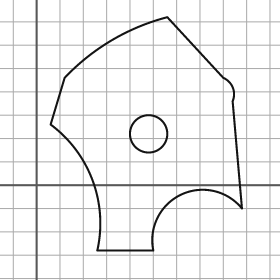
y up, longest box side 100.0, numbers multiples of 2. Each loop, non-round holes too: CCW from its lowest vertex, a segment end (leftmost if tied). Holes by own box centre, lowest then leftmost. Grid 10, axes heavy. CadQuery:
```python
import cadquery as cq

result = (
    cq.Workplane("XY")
    .moveTo(26.0, -28.0)
    .lineTo(50.0, -28.0)
    .threePointArc((62.0, -4.0), (88.0, -10.0))
    .lineTo(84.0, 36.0)
    .threePointArc((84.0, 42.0), (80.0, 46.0))
    .lineTo(56.0, 72.0)
    .threePointArc((32.0, 62.0), (12.0, 46.0))
    .lineTo(6.0, 26.0)
    .threePointArc((24.0, 2.0), (26.0, -28.0))
    .close()
    .moveTo(48.0, 22.0)
    .circle(8.0)
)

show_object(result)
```